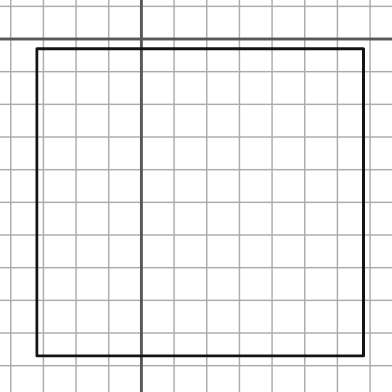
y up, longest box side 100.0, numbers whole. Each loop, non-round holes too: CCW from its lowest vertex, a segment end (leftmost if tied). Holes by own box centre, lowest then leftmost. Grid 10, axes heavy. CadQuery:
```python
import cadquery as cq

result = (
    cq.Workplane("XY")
    .moveTo(-32.0, -97.0)
    .lineTo(68.0, -97.0)
    .lineTo(68.0, -3.0)
    .lineTo(-32.0, -3.0)
    .close()
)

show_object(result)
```